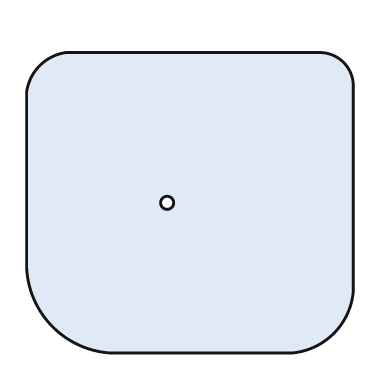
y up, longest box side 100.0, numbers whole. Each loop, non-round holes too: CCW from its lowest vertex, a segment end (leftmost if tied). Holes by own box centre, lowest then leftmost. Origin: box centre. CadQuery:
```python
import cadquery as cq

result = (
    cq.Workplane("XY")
    .moveTo(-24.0, -46.0)
    .lineTo(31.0, -46.0)
    .threePointArc((44.0, -40.0), (50.0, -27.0))
    .lineTo(50.0, 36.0)
    .threePointArc((47.0, 43.0), (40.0, 46.0))
    .lineTo(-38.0, 46.0)
    .threePointArc((-46.0, 42.0), (-50.0, 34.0))
    .lineTo(-50.0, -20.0)
    .threePointArc((-42.0, -38.0), (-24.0, -46.0))
    .close()
    .moveTo(-7.0, 0.0)
    .circle(2.0)
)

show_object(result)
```